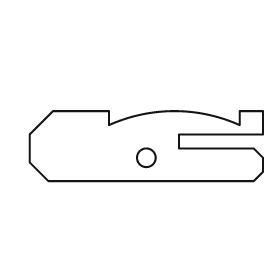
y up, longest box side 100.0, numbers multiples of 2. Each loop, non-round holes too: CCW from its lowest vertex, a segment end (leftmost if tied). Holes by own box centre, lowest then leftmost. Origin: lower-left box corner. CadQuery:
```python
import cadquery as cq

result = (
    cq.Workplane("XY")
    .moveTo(8.0, 0.0)
    .lineTo(96.0, 0.0)
    .lineTo(100.0, 4.0)
    .lineTo(100.0, 10.0)
    .lineTo(96.0, 14.0)
    .lineTo(64.0, 14.0)
    .lineTo(64.0, 20.0)
    .lineTo(100.0, 20.0)
    .lineTo(100.0, 30.0)
    .lineTo(90.0, 30.0)
    .lineTo(90.0, 24.0)
    .threePointArc((62.0, 30.0), (34.0, 24.0))
    .lineTo(34.0, 30.0)
    .lineTo(10.0, 30.0)
    .lineTo(0.0, 20.0)
    .lineTo(0.0, 8.0)
    .close()
    .moveTo(50.0, 10.0)
    .circle(4.0)
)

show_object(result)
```